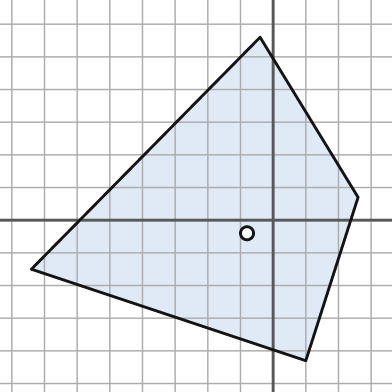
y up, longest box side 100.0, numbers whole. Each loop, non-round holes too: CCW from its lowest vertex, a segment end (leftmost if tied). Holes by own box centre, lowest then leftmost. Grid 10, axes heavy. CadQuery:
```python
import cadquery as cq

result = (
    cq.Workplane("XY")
    .moveTo(10.0, -43.0)
    .lineTo(26.0, 7.0)
    .lineTo(-4.0, 56.0)
    .lineTo(-74.0, -15.0)
    .close()
    .moveTo(-8.0, -4.0)
    .circle(2.0)
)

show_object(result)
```